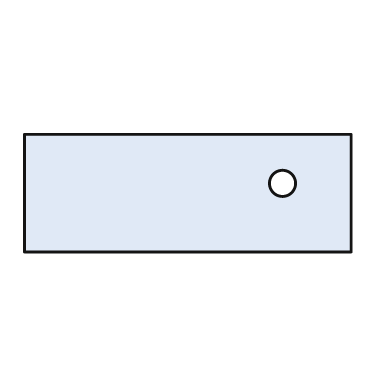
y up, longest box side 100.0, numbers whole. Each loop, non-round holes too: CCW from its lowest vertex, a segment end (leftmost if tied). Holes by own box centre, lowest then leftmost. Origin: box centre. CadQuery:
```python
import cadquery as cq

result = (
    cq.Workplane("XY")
    .moveTo(-50.0, -18.0)
    .lineTo(50.0, -18.0)
    .lineTo(50.0, 18.0)
    .lineTo(-50.0, 18.0)
    .close()
    .moveTo(29.0, 3.0)
    .circle(4.0)
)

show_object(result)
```